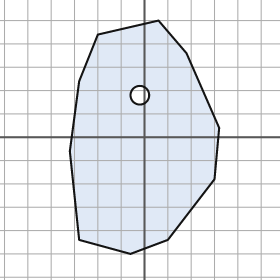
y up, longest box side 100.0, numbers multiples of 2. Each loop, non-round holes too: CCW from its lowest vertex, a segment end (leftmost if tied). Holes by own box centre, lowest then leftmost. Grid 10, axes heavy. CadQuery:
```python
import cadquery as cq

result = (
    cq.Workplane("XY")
    .moveTo(-6.0, -50.0)
    .lineTo(10.0, -44.0)
    .lineTo(30.0, -18.0)
    .lineTo(32.0, 4.0)
    .lineTo(18.0, 36.0)
    .lineTo(6.0, 50.0)
    .lineTo(-20.0, 44.0)
    .lineTo(-28.0, 24.0)
    .lineTo(-32.0, -6.0)
    .lineTo(-28.0, -44.0)
    .close()
    .moveTo(-2.0, 18.0)
    .circle(4.0)
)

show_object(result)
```